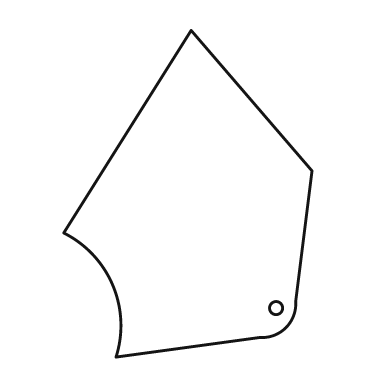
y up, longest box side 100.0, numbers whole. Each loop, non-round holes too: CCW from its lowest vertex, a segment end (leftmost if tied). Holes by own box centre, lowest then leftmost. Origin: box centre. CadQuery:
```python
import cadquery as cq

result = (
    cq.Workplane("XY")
    .moveTo(-22.0, -50.0)
    .lineTo(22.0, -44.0)
    .threePointArc((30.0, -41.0), (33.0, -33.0))
    .lineTo(38.0, 7.0)
    .lineTo(1.0, 50.0)
    .lineTo(-38.0, -12.0)
    .threePointArc((-23.0, -28.0), (-22.0, -50.0))
    .close()
    .moveTo(27.0, -35.0)
    .circle(2.0)
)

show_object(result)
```